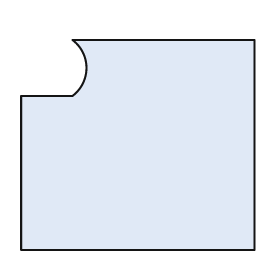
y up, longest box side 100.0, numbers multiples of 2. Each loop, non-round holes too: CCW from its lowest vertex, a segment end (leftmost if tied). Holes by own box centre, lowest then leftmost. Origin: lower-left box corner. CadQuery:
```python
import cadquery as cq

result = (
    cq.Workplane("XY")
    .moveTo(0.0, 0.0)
    .lineTo(100.0, 0.0)
    .lineTo(100.0, 90.0)
    .lineTo(22.0, 90.0)
    .threePointArc((28.0, 78.0), (22.0, 66.0))
    .lineTo(0.0, 66.0)
    .close()
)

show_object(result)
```